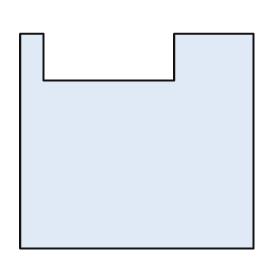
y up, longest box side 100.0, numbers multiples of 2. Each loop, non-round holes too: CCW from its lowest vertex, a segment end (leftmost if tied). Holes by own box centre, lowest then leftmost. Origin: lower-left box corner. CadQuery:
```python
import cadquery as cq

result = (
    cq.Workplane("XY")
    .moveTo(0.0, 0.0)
    .lineTo(100.0, 0.0)
    .lineTo(100.0, 92.0)
    .lineTo(66.0, 92.0)
    .lineTo(66.0, 72.0)
    .lineTo(10.0, 72.0)
    .lineTo(10.0, 92.0)
    .lineTo(0.0, 92.0)
    .close()
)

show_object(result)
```